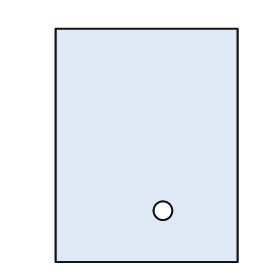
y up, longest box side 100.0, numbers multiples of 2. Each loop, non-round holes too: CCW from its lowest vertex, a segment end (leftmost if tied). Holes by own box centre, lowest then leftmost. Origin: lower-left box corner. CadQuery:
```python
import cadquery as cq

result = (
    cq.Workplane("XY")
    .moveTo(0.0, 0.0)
    .lineTo(78.0, 0.0)
    .lineTo(78.0, 100.0)
    .lineTo(0.0, 100.0)
    .close()
    .moveTo(46.0, 22.0)
    .circle(4.0)
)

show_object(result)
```